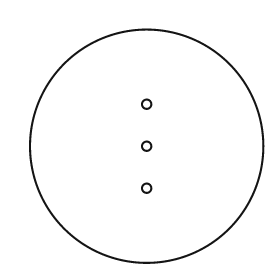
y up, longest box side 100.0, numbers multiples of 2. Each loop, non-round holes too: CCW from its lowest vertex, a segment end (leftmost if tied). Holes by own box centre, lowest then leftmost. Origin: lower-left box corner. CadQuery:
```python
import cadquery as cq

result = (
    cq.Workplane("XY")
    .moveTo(50.0, 50.0)
    .circle(50.0)
    .moveTo(50.0, 32.0)
    .circle(2.0)
    .moveTo(50.0, 50.0)
    .circle(2.0)
    .moveTo(50.0, 68.0)
    .circle(2.0)
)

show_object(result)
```